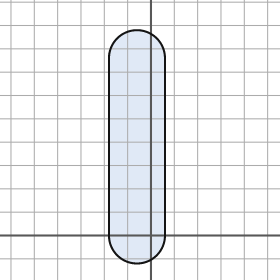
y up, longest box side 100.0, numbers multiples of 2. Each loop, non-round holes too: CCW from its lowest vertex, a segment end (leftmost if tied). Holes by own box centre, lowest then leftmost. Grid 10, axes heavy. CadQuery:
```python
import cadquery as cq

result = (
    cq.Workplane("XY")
    .moveTo(-18.0, 0.0)
    .threePointArc((-6.0, -12.0), (6.0, 0.0))
    .lineTo(6.0, 76.0)
    .threePointArc((-6.0, 88.0), (-18.0, 76.0))
    .close()
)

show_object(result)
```